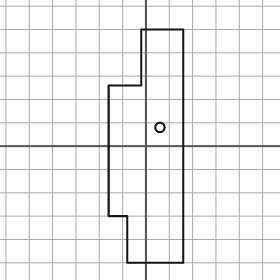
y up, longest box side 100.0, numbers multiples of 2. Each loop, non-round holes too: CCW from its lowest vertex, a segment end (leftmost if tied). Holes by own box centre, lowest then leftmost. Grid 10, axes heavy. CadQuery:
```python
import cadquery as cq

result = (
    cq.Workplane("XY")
    .moveTo(-8.0, -50.0)
    .lineTo(16.0, -50.0)
    .lineTo(16.0, 50.0)
    .lineTo(-2.0, 50.0)
    .lineTo(-2.0, 26.0)
    .lineTo(-16.0, 26.0)
    .lineTo(-16.0, -30.0)
    .lineTo(-8.0, -30.0)
    .close()
    .moveTo(6.0, 8.0)
    .circle(2.0)
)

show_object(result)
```